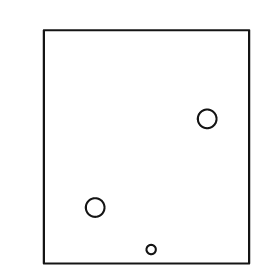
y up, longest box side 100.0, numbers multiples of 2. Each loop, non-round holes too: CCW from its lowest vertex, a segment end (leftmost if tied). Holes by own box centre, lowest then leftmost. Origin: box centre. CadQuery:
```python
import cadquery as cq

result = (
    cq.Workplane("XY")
    .moveTo(-44.0, -50.0)
    .lineTo(44.0, -50.0)
    .lineTo(44.0, 50.0)
    .lineTo(-44.0, 50.0)
    .close()
    .moveTo(2.0, -44.0)
    .circle(2.0)
    .moveTo(-22.0, -26.0)
    .circle(4.0)
    .moveTo(26.0, 12.0)
    .circle(4.0)
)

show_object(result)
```